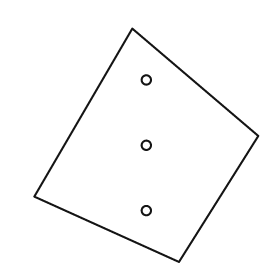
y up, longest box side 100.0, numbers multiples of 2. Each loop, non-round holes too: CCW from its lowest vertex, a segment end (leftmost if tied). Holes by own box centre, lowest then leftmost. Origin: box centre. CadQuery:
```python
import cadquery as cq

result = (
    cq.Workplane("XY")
    .moveTo(14.0, -50.0)
    .lineTo(48.0, 4.0)
    .lineTo(-6.0, 50.0)
    .lineTo(-48.0, -22.0)
    .close()
    .moveTo(0.0, -28.0)
    .circle(2.0)
    .moveTo(0.0, 0.0)
    .circle(2.0)
    .moveTo(0.0, 28.0)
    .circle(2.0)
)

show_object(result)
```